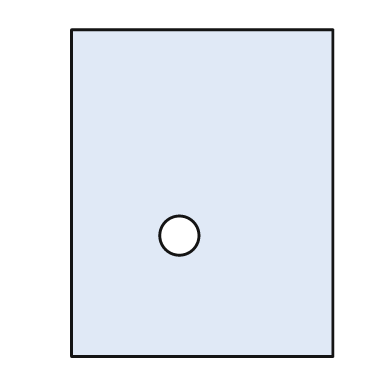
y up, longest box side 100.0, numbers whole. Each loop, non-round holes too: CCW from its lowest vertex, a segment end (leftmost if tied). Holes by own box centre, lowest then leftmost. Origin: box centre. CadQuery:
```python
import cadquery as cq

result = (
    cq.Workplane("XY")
    .moveTo(-40.0, -50.0)
    .lineTo(40.0, -50.0)
    .lineTo(40.0, 50.0)
    .lineTo(-40.0, 50.0)
    .close()
    .moveTo(-7.0, -13.0)
    .circle(6.0)
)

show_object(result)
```